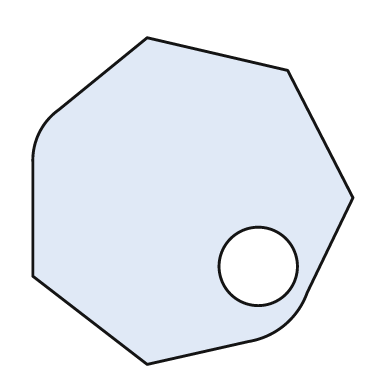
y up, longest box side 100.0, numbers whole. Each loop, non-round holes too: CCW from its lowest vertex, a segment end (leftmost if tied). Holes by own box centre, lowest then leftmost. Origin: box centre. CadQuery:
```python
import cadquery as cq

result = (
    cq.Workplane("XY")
    .moveTo(-14.0, -50.0)
    .lineTo(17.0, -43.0)
    .threePointArc((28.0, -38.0), (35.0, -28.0))
    .lineTo(49.0, 1.0)
    .lineTo(29.0, 40.0)
    .lineTo(-14.0, 50.0)
    .lineTo(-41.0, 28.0)
    .threePointArc((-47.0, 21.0), (-49.0, 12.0))
    .lineTo(-49.0, -23.0)
    .close()
    .moveTo(20.0, -20.0)
    .circle(12.0)
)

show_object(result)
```